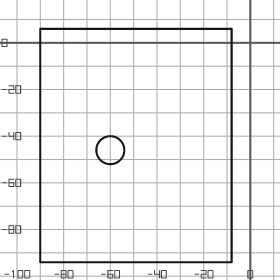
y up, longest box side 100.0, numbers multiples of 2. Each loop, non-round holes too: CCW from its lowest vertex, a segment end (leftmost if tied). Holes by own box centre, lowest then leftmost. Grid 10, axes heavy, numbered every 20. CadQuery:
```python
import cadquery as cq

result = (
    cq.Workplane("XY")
    .moveTo(-90.0, -94.0)
    .lineTo(-8.0, -94.0)
    .lineTo(-8.0, 6.0)
    .lineTo(-90.0, 6.0)
    .close()
    .moveTo(-60.0, -46.0)
    .circle(6.0)
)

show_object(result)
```